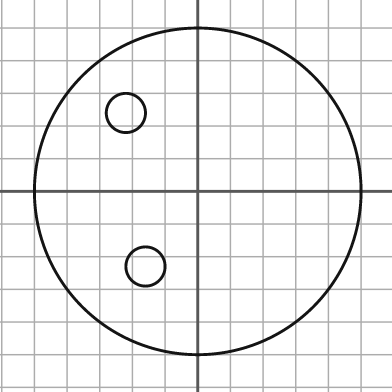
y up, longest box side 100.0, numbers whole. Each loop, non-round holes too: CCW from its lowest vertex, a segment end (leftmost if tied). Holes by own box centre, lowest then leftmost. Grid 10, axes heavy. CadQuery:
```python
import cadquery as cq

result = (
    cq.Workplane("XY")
    .moveTo(0.0, 0.0)
    .circle(50.0)
    .moveTo(-16.0, -23.0)
    .circle(6.0)
    .moveTo(-22.0, 24.0)
    .circle(6.0)
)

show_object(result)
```